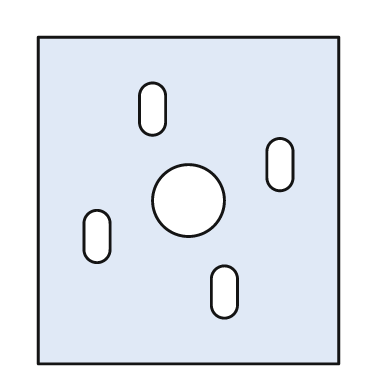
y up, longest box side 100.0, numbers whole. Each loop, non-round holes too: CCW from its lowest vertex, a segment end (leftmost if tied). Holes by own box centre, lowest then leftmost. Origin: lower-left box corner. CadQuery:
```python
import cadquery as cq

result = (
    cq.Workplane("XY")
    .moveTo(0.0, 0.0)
    .lineTo(92.0, 0.0)
    .lineTo(92.0, 100.0)
    .lineTo(0.0, 100.0)
    .close()
    .moveTo(53.0, 18.0)
    .threePointArc((57.0, 14.0), (61.0, 18.0))
    .lineTo(61.0, 26.0)
    .threePointArc((57.0, 30.0), (53.0, 26.0))
    .close()
    .moveTo(14.0, 35.0)
    .threePointArc((18.0, 31.0), (22.0, 35.0))
    .lineTo(22.0, 43.0)
    .threePointArc((18.0, 47.0), (14.0, 43.0))
    .close()
    .moveTo(46.0, 50.0)
    .circle(11.0)
    .moveTo(70.0, 57.0)
    .threePointArc((74.0, 53.0), (78.0, 57.0))
    .lineTo(78.0, 65.0)
    .threePointArc((74.0, 69.0), (70.0, 65.0))
    .close()
    .moveTo(31.0, 74.0)
    .threePointArc((35.0, 70.0), (39.0, 74.0))
    .lineTo(39.0, 82.0)
    .threePointArc((35.0, 86.0), (31.0, 82.0))
    .close()
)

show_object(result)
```